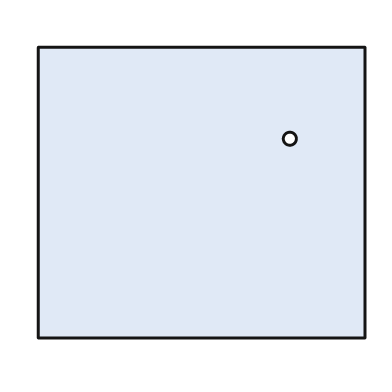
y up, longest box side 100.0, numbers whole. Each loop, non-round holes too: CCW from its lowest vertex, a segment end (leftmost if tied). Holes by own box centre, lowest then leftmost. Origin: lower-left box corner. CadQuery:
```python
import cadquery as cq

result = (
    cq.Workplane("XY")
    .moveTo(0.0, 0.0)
    .lineTo(100.0, 0.0)
    .lineTo(100.0, 89.0)
    .lineTo(0.0, 89.0)
    .close()
    .moveTo(77.0, 61.0)
    .circle(2.0)
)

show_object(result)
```